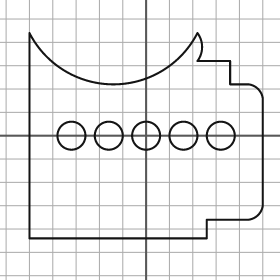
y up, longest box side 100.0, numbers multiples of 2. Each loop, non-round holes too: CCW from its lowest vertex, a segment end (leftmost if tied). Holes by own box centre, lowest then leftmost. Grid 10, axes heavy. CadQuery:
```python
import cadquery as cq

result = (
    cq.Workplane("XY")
    .moveTo(-50.0, -44.0)
    .lineTo(26.0, -44.0)
    .lineTo(26.0, -36.0)
    .lineTo(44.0, -36.0)
    .threePointArc((48.0, -34.0), (50.0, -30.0))
    .lineTo(50.0, 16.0)
    .threePointArc((48.0, 20.0), (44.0, 22.0))
    .lineTo(36.0, 22.0)
    .lineTo(36.0, 32.0)
    .lineTo(22.0, 32.0)
    .threePointArc((24.0, 38.0), (22.0, 44.0))
    .threePointArc((-14.0, 22.0), (-50.0, 44.0))
    .close()
    .moveTo(-32.0, 0.0)
    .circle(6.0)
    .moveTo(-16.0, 0.0)
    .circle(6.0)
    .moveTo(0.0, 0.0)
    .circle(6.0)
    .moveTo(16.0, 0.0)
    .circle(6.0)
    .moveTo(32.0, 0.0)
    .circle(6.0)
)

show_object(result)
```